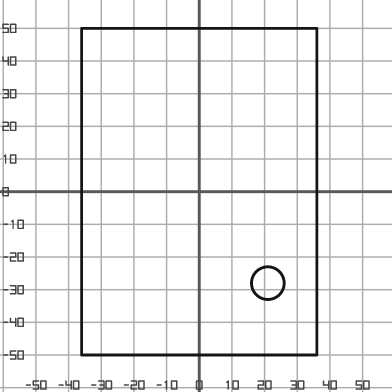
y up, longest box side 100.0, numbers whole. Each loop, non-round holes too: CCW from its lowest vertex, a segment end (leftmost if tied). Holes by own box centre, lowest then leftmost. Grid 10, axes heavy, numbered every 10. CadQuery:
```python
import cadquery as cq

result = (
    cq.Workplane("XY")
    .moveTo(-36.0, -50.0)
    .lineTo(36.0, -50.0)
    .lineTo(36.0, 50.0)
    .lineTo(-36.0, 50.0)
    .close()
    .moveTo(21.0, -28.0)
    .circle(5.0)
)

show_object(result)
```